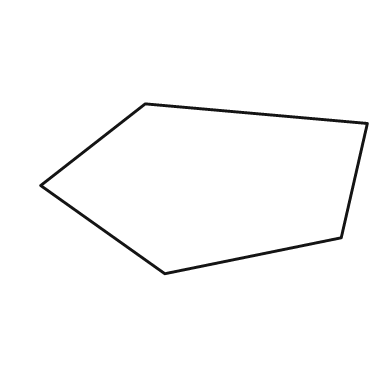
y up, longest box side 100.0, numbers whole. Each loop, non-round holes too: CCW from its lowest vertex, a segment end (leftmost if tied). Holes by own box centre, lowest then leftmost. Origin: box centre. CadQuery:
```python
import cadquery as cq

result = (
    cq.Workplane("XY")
    .moveTo(-12.0, -26.0)
    .lineTo(42.0, -15.0)
    .lineTo(50.0, 20.0)
    .lineTo(-18.0, 26.0)
    .lineTo(-50.0, 1.0)
    .close()
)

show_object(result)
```